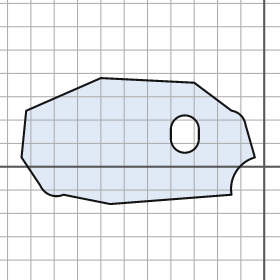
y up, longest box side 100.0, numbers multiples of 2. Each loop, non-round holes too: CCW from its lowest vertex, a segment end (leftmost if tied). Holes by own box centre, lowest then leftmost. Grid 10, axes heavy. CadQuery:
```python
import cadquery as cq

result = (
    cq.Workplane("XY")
    .moveTo(-66.0, -16.0)
    .lineTo(-14.0, -12.0)
    .threePointArc((-12.0, -2.0), (-4.0, 4.0))
    .lineTo(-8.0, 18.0)
    .threePointArc((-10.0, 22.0), (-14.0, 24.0))
    .lineTo(-30.0, 36.0)
    .lineTo(-70.0, 38.0)
    .lineTo(-102.0, 24.0)
    .lineTo(-104.0, 4.0)
    .lineTo(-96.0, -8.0)
    .threePointArc((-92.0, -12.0), (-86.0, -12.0))
    .close()
    .moveTo(-40.0, 12.0)
    .threePointArc((-34.0, 6.0), (-28.0, 12.0))
    .lineTo(-28.0, 16.0)
    .threePointArc((-34.0, 22.0), (-40.0, 16.0))
    .close()
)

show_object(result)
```